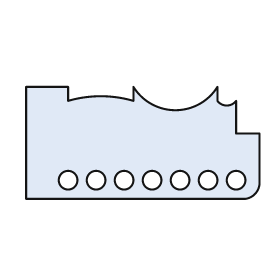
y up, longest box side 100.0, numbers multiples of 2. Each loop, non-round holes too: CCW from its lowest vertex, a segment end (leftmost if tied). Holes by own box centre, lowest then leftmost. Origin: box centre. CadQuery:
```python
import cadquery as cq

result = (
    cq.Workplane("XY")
    .moveTo(-50.0, -24.0)
    .lineTo(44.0, -24.0)
    .threePointArc((48.0, -22.0), (50.0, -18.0))
    .lineTo(50.0, 4.0)
    .lineTo(40.0, 4.0)
    .lineTo(40.0, 18.0)
    .threePointArc((36.0, 16.0), (32.0, 18.0))
    .lineTo(32.0, 24.0)
    .threePointArc((14.0, 14.0), (-4.0, 24.0))
    .lineTo(-4.0, 18.0)
    .threePointArc((-18.0, 20.0), (-32.0, 18.0))
    .lineTo(-32.0, 24.0)
    .lineTo(-50.0, 24.0)
    .close()
    .moveTo(-32.0, -16.0)
    .circle(4.0)
    .moveTo(-20.0, -16.0)
    .circle(4.0)
    .moveTo(-8.0, -16.0)
    .circle(4.0)
    .moveTo(4.0, -16.0)
    .circle(4.0)
    .moveTo(16.0, -16.0)
    .circle(4.0)
    .moveTo(28.0, -16.0)
    .circle(4.0)
    .moveTo(40.0, -16.0)
    .circle(4.0)
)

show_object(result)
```